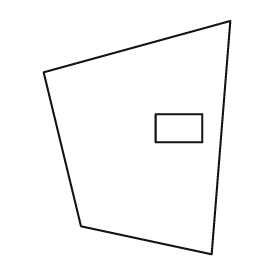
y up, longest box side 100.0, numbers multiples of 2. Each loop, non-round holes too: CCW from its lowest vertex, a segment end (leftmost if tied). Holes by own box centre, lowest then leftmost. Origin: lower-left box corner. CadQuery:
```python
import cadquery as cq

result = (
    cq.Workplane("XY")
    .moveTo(72.0, 0.0)
    .lineTo(80.0, 100.0)
    .lineTo(0.0, 78.0)
    .lineTo(16.0, 12.0)
    .close()
    .moveTo(48.0, 48.0)
    .lineTo(68.0, 48.0)
    .lineTo(68.0, 60.0)
    .lineTo(48.0, 60.0)
    .close()
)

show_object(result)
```